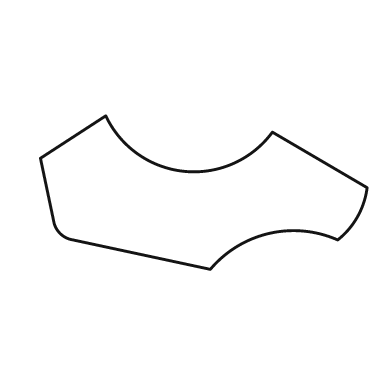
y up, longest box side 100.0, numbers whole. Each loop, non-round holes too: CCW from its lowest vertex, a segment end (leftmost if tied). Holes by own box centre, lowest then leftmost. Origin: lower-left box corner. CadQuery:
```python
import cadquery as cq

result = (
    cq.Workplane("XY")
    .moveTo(52.0, 0.0)
    .threePointArc((70.0, 11.0), (91.0, 9.0))
    .threePointArc((97.0, 16.0), (100.0, 25.0))
    .lineTo(71.0, 42.0)
    .threePointArc((44.0, 30.0), (20.0, 47.0))
    .lineTo(0.0, 34.0)
    .lineTo(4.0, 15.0)
    .threePointArc((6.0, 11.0), (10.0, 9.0))
    .close()
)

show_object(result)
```